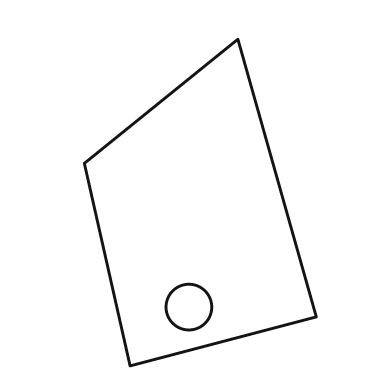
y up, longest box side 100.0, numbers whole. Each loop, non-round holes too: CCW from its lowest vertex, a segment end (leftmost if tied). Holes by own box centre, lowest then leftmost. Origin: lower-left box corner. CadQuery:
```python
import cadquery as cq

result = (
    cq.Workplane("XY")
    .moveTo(14.0, 0.0)
    .lineTo(71.0, 15.0)
    .lineTo(47.0, 100.0)
    .lineTo(0.0, 62.0)
    .close()
    .moveTo(32.0, 18.0)
    .circle(7.0)
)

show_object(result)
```